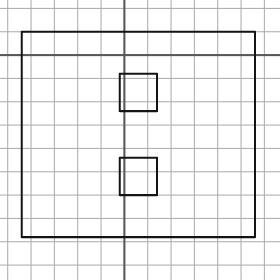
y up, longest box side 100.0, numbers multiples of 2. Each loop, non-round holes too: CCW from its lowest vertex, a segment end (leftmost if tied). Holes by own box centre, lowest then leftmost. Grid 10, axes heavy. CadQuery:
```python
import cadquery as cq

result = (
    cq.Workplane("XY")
    .moveTo(-44.0, -78.0)
    .lineTo(56.0, -78.0)
    .lineTo(56.0, 10.0)
    .lineTo(-44.0, 10.0)
    .close()
    .moveTo(-2.0, -60.0)
    .lineTo(14.0, -60.0)
    .lineTo(14.0, -44.0)
    .lineTo(-2.0, -44.0)
    .close()
    .moveTo(-2.0, -24.0)
    .lineTo(14.0, -24.0)
    .lineTo(14.0, -8.0)
    .lineTo(-2.0, -8.0)
    .close()
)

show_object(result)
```